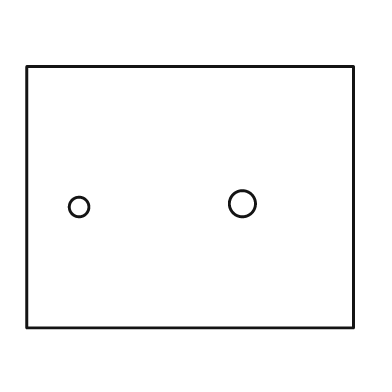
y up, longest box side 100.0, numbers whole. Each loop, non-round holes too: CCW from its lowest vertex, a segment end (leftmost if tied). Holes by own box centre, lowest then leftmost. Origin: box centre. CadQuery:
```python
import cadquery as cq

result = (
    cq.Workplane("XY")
    .moveTo(-50.0, -40.0)
    .lineTo(50.0, -40.0)
    .lineTo(50.0, 40.0)
    .lineTo(-50.0, 40.0)
    .close()
    .moveTo(-34.0, -3.0)
    .circle(3.0)
    .moveTo(16.0, -2.0)
    .circle(4.0)
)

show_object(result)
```